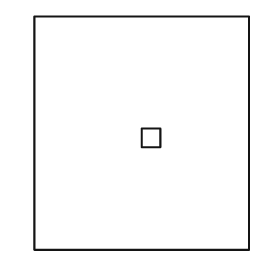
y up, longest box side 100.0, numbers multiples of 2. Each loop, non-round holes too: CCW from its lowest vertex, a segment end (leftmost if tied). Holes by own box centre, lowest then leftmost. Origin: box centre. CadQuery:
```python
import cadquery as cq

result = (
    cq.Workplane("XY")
    .moveTo(-46.0, -50.0)
    .lineTo(46.0, -50.0)
    .lineTo(46.0, 50.0)
    .lineTo(-46.0, 50.0)
    .close()
    .moveTo(0.0, -6.0)
    .lineTo(8.0, -6.0)
    .lineTo(8.0, 2.0)
    .lineTo(0.0, 2.0)
    .close()
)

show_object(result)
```